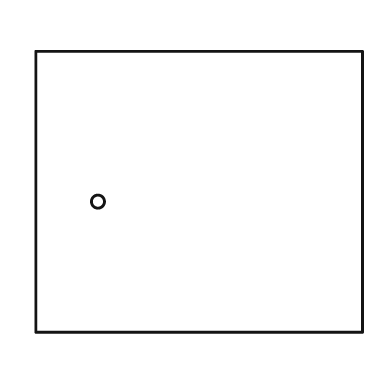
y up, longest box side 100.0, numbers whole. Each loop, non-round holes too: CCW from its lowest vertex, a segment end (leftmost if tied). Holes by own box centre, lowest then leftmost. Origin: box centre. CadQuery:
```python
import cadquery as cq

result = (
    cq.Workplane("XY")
    .moveTo(-50.0, -43.0)
    .lineTo(50.0, -43.0)
    .lineTo(50.0, 43.0)
    .lineTo(-50.0, 43.0)
    .close()
    .moveTo(-31.0, -3.0)
    .circle(2.0)
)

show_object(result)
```